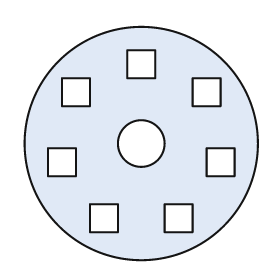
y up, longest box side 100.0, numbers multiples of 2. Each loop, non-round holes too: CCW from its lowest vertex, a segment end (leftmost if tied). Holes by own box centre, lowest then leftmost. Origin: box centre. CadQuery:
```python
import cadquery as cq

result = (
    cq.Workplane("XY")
    .moveTo(0.0, 0.0)
    .circle(50.0)
    .moveTo(-22.0, -38.0)
    .lineTo(-10.0, -38.0)
    .lineTo(-10.0, -26.0)
    .lineTo(-22.0, -26.0)
    .close()
    .moveTo(10.0, -38.0)
    .lineTo(22.0, -38.0)
    .lineTo(22.0, -26.0)
    .lineTo(10.0, -26.0)
    .close()
    .moveTo(-40.0, -14.0)
    .lineTo(-28.0, -14.0)
    .lineTo(-28.0, -2.0)
    .lineTo(-40.0, -2.0)
    .close()
    .moveTo(28.0, -14.0)
    .lineTo(40.0, -14.0)
    .lineTo(40.0, -2.0)
    .lineTo(28.0, -2.0)
    .close()
    .moveTo(0.0, 0.0)
    .circle(10.0)
    .moveTo(-34.0, 16.0)
    .lineTo(-22.0, 16.0)
    .lineTo(-22.0, 28.0)
    .lineTo(-34.0, 28.0)
    .close()
    .moveTo(22.0, 16.0)
    .lineTo(34.0, 16.0)
    .lineTo(34.0, 28.0)
    .lineTo(22.0, 28.0)
    .close()
    .moveTo(-6.0, 28.0)
    .lineTo(6.0, 28.0)
    .lineTo(6.0, 40.0)
    .lineTo(-6.0, 40.0)
    .close()
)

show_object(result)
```